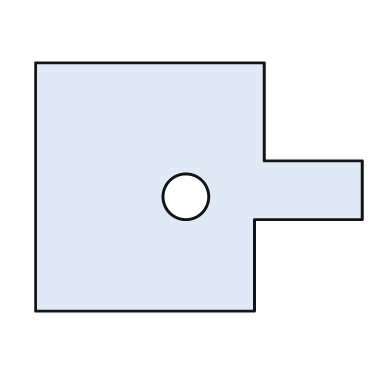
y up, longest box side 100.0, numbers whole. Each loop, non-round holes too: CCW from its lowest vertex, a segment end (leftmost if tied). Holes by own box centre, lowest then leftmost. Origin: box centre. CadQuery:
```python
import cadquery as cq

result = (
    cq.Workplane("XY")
    .moveTo(-50.0, -38.0)
    .lineTo(17.0, -38.0)
    .lineTo(17.0, -10.0)
    .lineTo(50.0, -10.0)
    .lineTo(50.0, 8.0)
    .lineTo(20.0, 8.0)
    .lineTo(20.0, 38.0)
    .lineTo(-50.0, 38.0)
    .close()
    .moveTo(-4.0, -3.0)
    .circle(7.0)
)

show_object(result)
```